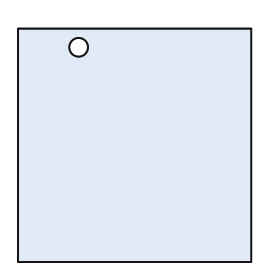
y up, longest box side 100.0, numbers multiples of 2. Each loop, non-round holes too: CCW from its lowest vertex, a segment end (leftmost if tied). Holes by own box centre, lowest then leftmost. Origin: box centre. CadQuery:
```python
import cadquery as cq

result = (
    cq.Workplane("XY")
    .moveTo(-50.0, -50.0)
    .lineTo(50.0, -50.0)
    .lineTo(50.0, 50.0)
    .lineTo(-50.0, 50.0)
    .close()
    .moveTo(-24.0, 42.0)
    .circle(4.0)
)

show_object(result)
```